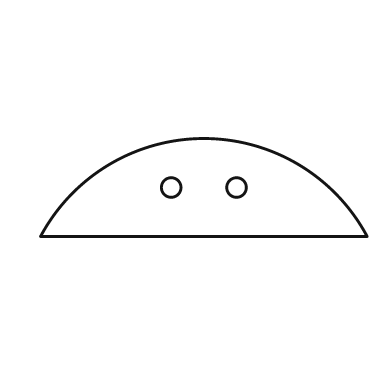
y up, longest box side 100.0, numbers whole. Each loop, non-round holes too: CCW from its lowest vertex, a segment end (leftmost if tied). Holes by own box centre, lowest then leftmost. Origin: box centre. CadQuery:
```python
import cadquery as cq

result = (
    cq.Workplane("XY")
    .moveTo(-50.0, -15.0)
    .lineTo(50.0, -15.0)
    .threePointArc((0.0, 15.0), (-50.0, -15.0))
    .close()
    .moveTo(-10.0, 0.0)
    .circle(3.0)
    .moveTo(10.0, 0.0)
    .circle(3.0)
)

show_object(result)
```